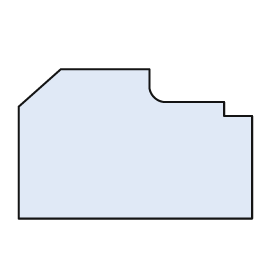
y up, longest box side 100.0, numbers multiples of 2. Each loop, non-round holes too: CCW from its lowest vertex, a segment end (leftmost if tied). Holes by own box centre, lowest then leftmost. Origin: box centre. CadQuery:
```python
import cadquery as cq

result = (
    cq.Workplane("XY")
    .moveTo(-50.0, -32.0)
    .lineTo(50.0, -32.0)
    .lineTo(50.0, 12.0)
    .lineTo(38.0, 12.0)
    .lineTo(38.0, 18.0)
    .lineTo(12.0, 18.0)
    .threePointArc((8.0, 20.0), (6.0, 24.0))
    .lineTo(6.0, 32.0)
    .lineTo(-32.0, 32.0)
    .lineTo(-50.0, 16.0)
    .close()
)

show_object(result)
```